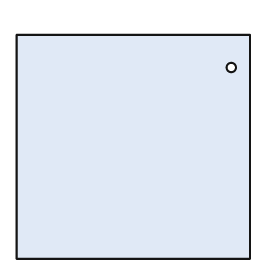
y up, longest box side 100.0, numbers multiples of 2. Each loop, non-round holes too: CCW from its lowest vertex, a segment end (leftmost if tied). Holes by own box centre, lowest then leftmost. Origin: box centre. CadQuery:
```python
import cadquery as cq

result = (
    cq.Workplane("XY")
    .moveTo(-50.0, -48.0)
    .lineTo(50.0, -48.0)
    .lineTo(50.0, 48.0)
    .lineTo(-50.0, 48.0)
    .close()
    .moveTo(42.0, 34.0)
    .circle(2.0)
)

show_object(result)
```